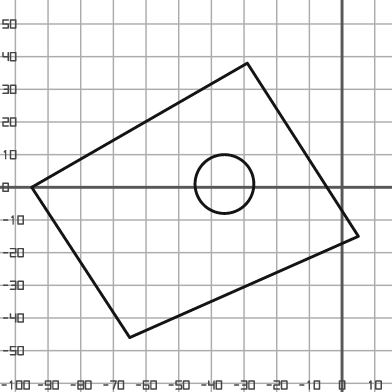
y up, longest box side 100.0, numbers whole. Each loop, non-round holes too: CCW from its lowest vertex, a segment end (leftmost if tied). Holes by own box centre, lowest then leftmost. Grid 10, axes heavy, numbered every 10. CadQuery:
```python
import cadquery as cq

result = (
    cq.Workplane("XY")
    .moveTo(-65.0, -46.0)
    .lineTo(5.0, -15.0)
    .lineTo(-29.0, 38.0)
    .lineTo(-95.0, 0.0)
    .close()
    .moveTo(-36.0, 1.0)
    .circle(9.0)
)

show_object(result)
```